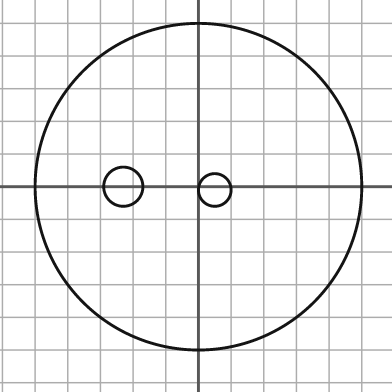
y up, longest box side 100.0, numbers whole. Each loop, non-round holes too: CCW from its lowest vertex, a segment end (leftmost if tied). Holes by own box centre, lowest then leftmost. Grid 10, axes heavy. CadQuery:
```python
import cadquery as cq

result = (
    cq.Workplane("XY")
    .moveTo(0.0, 0.0)
    .circle(50.0)
    .moveTo(5.0, -1.0)
    .circle(5.0)
    .moveTo(-23.0, 0.0)
    .circle(6.0)
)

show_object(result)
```